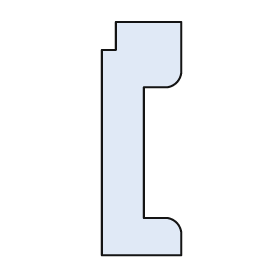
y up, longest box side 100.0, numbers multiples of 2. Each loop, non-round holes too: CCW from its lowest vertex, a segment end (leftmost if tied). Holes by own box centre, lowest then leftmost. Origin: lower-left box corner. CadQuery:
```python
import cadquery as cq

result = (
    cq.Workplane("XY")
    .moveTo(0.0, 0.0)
    .lineTo(34.0, 0.0)
    .lineTo(34.0, 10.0)
    .threePointArc((32.0, 14.0), (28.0, 16.0))
    .lineTo(18.0, 16.0)
    .lineTo(18.0, 72.0)
    .lineTo(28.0, 72.0)
    .threePointArc((32.0, 74.0), (34.0, 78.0))
    .lineTo(34.0, 100.0)
    .lineTo(6.0, 100.0)
    .lineTo(6.0, 88.0)
    .lineTo(0.0, 88.0)
    .close()
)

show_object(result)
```